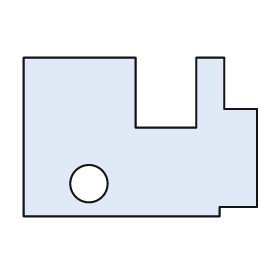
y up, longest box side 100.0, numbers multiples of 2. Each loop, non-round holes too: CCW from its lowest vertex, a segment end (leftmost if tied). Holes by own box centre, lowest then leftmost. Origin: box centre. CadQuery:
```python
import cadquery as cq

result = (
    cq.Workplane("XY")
    .moveTo(-50.0, -34.0)
    .lineTo(34.0, -34.0)
    .lineTo(34.0, -30.0)
    .lineTo(50.0, -30.0)
    .lineTo(50.0, 12.0)
    .lineTo(36.0, 12.0)
    .lineTo(36.0, 34.0)
    .lineTo(24.0, 34.0)
    .lineTo(24.0, 4.0)
    .lineTo(-2.0, 4.0)
    .lineTo(-2.0, 34.0)
    .lineTo(-50.0, 34.0)
    .close()
    .moveTo(-22.0, -20.0)
    .circle(8.0)
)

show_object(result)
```